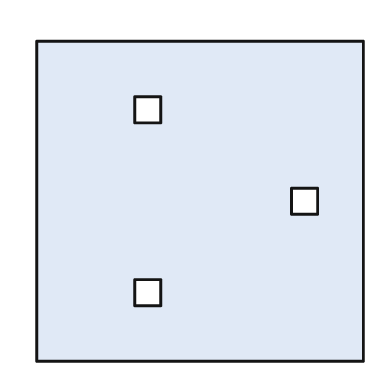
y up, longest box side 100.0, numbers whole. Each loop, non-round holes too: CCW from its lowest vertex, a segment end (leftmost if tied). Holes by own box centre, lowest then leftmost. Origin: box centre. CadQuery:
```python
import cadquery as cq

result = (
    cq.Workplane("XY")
    .moveTo(-50.0, -49.0)
    .lineTo(50.0, -49.0)
    .lineTo(50.0, 49.0)
    .lineTo(-50.0, 49.0)
    .close()
    .moveTo(-20.0, -32.0)
    .lineTo(-12.0, -32.0)
    .lineTo(-12.0, -24.0)
    .lineTo(-20.0, -24.0)
    .close()
    .moveTo(28.0, -4.0)
    .lineTo(36.0, -4.0)
    .lineTo(36.0, 4.0)
    .lineTo(28.0, 4.0)
    .close()
    .moveTo(-20.0, 24.0)
    .lineTo(-12.0, 24.0)
    .lineTo(-12.0, 32.0)
    .lineTo(-20.0, 32.0)
    .close()
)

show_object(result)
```